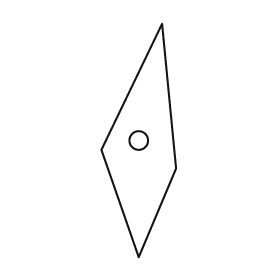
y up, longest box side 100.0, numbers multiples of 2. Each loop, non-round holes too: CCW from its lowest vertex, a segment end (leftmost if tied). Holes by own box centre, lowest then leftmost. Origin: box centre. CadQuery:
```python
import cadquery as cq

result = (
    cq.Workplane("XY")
    .moveTo(0.0, -50.0)
    .lineTo(16.0, -12.0)
    .lineTo(10.0, 50.0)
    .lineTo(-16.0, -4.0)
    .close()
    .moveTo(0.0, 0.0)
    .circle(4.0)
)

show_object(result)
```